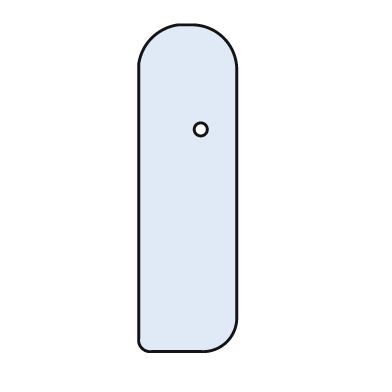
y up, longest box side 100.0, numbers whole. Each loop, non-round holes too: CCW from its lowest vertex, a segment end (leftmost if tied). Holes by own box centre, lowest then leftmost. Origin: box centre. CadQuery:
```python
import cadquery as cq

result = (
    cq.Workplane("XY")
    .moveTo(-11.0, -50.0)
    .lineTo(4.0, -50.0)
    .threePointArc((12.0, -47.0), (15.0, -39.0))
    .lineTo(15.0, 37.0)
    .threePointArc((11.0, 46.0), (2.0, 50.0))
    .lineTo(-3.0, 50.0)
    .threePointArc((-11.0, 46.0), (-15.0, 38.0))
    .lineTo(-15.0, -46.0)
    .threePointArc((-14.0, -49.0), (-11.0, -50.0))
    .close()
    .moveTo(4.0, 18.0)
    .circle(2.0)
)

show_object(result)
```